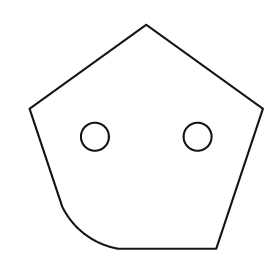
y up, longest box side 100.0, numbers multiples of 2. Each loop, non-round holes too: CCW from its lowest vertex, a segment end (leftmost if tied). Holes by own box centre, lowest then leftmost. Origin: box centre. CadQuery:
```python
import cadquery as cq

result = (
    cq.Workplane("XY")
    .moveTo(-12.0, -48.0)
    .lineTo(30.0, -48.0)
    .lineTo(50.0, 12.0)
    .lineTo(0.0, 48.0)
    .lineTo(-50.0, 12.0)
    .lineTo(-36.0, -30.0)
    .threePointArc((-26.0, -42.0), (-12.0, -48.0))
    .close()
    .moveTo(-22.0, 0.0)
    .circle(6.0)
    .moveTo(22.0, 0.0)
    .circle(6.0)
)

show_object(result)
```